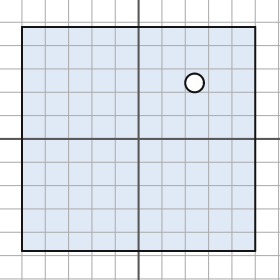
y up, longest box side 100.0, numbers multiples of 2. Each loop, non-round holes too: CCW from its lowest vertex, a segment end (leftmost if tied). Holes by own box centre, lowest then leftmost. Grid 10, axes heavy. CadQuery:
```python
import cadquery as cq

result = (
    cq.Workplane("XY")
    .moveTo(-50.0, -48.0)
    .lineTo(50.0, -48.0)
    .lineTo(50.0, 48.0)
    .lineTo(-50.0, 48.0)
    .close()
    .moveTo(24.0, 24.0)
    .circle(4.0)
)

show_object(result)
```